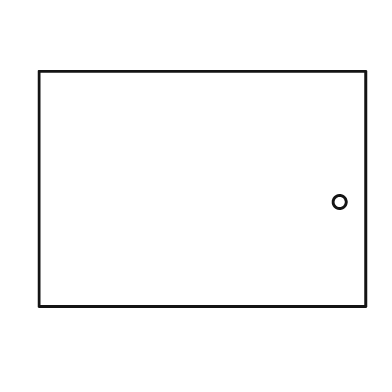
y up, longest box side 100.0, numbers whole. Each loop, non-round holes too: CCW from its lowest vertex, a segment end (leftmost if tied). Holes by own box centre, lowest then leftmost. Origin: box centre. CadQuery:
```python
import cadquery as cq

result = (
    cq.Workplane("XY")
    .moveTo(-50.0, -36.0)
    .lineTo(50.0, -36.0)
    .lineTo(50.0, 36.0)
    .lineTo(-50.0, 36.0)
    .close()
    .moveTo(42.0, -4.0)
    .circle(2.0)
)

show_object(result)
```